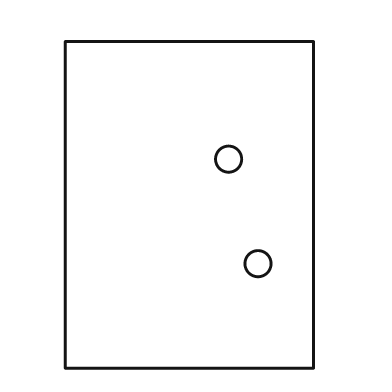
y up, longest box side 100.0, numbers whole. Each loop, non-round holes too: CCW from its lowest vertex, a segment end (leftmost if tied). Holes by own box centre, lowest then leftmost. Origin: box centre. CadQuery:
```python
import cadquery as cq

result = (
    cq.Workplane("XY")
    .moveTo(-38.0, -50.0)
    .lineTo(38.0, -50.0)
    .lineTo(38.0, 50.0)
    .lineTo(-38.0, 50.0)
    .close()
    .moveTo(21.0, -18.0)
    .circle(4.0)
    .moveTo(12.0, 14.0)
    .circle(4.0)
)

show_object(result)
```